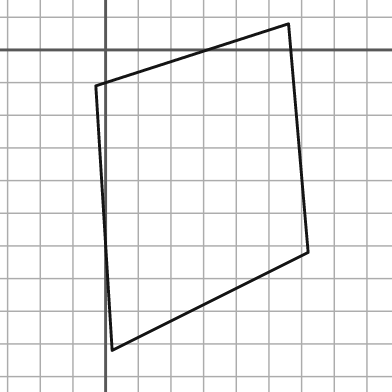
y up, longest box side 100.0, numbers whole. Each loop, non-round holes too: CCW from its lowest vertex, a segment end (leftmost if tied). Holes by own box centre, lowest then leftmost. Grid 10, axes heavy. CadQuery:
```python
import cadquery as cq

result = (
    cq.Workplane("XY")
    .moveTo(2.0, -92.0)
    .lineTo(62.0, -62.0)
    .lineTo(56.0, 8.0)
    .lineTo(-3.0, -11.0)
    .close()
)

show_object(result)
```